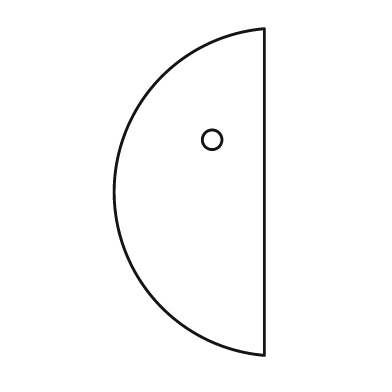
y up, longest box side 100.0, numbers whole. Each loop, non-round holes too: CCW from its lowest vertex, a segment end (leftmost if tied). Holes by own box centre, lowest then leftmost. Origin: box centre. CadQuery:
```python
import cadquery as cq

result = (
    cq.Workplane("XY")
    .moveTo(23.0, -50.0)
    .lineTo(23.0, 50.0)
    .threePointArc((-23.0, 0.0), (23.0, -50.0))
    .close()
    .moveTo(7.0, 16.0)
    .circle(3.0)
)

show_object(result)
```